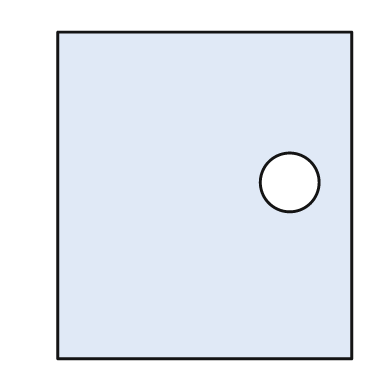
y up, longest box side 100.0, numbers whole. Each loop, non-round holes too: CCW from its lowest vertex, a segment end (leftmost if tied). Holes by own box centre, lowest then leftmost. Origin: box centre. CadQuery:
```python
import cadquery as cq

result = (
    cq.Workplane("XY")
    .moveTo(-45.0, -50.0)
    .lineTo(45.0, -50.0)
    .lineTo(45.0, 50.0)
    .lineTo(-45.0, 50.0)
    .close()
    .moveTo(26.0, 4.0)
    .circle(9.0)
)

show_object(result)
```